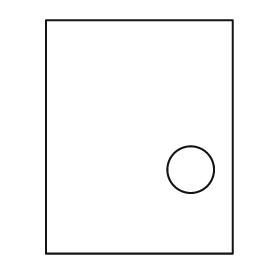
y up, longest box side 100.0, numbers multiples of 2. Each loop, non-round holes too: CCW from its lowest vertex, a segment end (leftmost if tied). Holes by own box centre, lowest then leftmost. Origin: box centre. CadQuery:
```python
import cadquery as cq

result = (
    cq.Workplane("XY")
    .moveTo(-40.0, -50.0)
    .lineTo(40.0, -50.0)
    .lineTo(40.0, 50.0)
    .lineTo(-40.0, 50.0)
    .close()
    .moveTo(22.0, -14.0)
    .circle(10.0)
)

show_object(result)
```